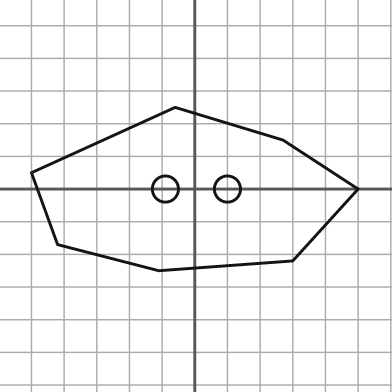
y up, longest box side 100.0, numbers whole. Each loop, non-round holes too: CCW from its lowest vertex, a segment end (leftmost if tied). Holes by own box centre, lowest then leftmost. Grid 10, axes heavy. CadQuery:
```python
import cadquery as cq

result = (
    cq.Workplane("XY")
    .moveTo(-11.0, -25.0)
    .lineTo(30.0, -22.0)
    .lineTo(50.0, 0.0)
    .lineTo(27.0, 15.0)
    .lineTo(-6.0, 25.0)
    .lineTo(-50.0, 5.0)
    .lineTo(-42.0, -17.0)
    .close()
    .moveTo(-9.0, 0.0)
    .circle(4.0)
    .moveTo(10.0, 0.0)
    .circle(4.0)
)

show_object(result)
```